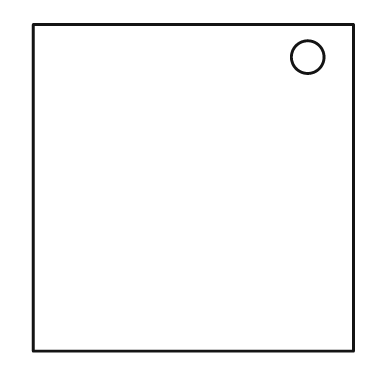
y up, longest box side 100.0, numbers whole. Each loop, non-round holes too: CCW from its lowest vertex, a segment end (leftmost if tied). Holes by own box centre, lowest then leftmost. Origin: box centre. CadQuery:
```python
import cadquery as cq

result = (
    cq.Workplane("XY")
    .moveTo(-49.0, -50.0)
    .lineTo(49.0, -50.0)
    .lineTo(49.0, 50.0)
    .lineTo(-49.0, 50.0)
    .close()
    .moveTo(35.0, 40.0)
    .circle(5.0)
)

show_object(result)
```